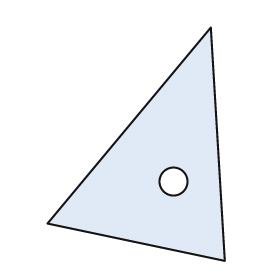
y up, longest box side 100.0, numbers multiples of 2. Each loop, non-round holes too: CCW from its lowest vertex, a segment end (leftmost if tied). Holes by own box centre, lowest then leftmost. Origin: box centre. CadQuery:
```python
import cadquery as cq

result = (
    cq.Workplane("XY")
    .moveTo(38.0, -50.0)
    .lineTo(32.0, 50.0)
    .lineTo(-38.0, -34.0)
    .close()
    .moveTo(16.0, -16.0)
    .circle(6.0)
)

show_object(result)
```